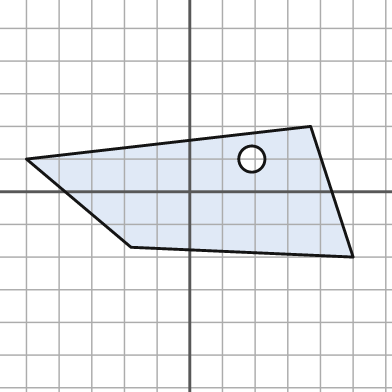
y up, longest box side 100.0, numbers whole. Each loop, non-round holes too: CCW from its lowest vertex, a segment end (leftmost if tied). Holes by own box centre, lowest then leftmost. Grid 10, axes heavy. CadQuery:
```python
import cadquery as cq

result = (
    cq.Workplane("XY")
    .moveTo(50.0, -20.0)
    .lineTo(37.0, 20.0)
    .lineTo(-50.0, 10.0)
    .lineTo(-18.0, -17.0)
    .close()
    .moveTo(19.0, 10.0)
    .circle(4.0)
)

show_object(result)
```